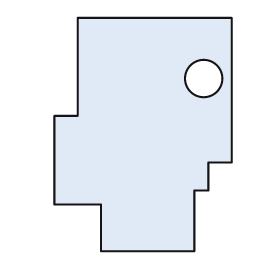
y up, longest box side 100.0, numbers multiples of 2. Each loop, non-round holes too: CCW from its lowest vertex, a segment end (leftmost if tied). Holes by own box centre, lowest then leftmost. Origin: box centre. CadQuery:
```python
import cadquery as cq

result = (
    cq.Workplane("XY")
    .moveTo(-18.0, -50.0)
    .lineTo(22.0, -50.0)
    .lineTo(22.0, -24.0)
    .lineTo(28.0, -24.0)
    .lineTo(28.0, -12.0)
    .lineTo(38.0, -12.0)
    .lineTo(38.0, 50.0)
    .lineTo(-28.0, 50.0)
    .lineTo(-28.0, 8.0)
    .lineTo(-38.0, 8.0)
    .lineTo(-38.0, -30.0)
    .lineTo(-18.0, -30.0)
    .close()
    .moveTo(26.0, 24.0)
    .circle(8.0)
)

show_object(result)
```